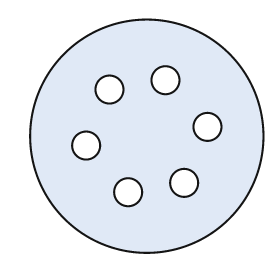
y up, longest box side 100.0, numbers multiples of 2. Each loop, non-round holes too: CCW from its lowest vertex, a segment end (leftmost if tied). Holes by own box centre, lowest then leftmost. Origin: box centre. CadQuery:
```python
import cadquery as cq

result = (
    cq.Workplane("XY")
    .moveTo(0.0, 0.0)
    .circle(50.0)
    .moveTo(-8.0, -24.0)
    .circle(6.0)
    .moveTo(16.0, -20.0)
    .circle(6.0)
    .moveTo(-26.0, -4.0)
    .circle(6.0)
    .moveTo(26.0, 4.0)
    .circle(6.0)
    .moveTo(-16.0, 20.0)
    .circle(6.0)
    .moveTo(8.0, 24.0)
    .circle(6.0)
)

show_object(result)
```